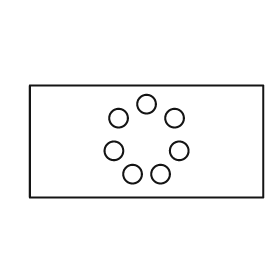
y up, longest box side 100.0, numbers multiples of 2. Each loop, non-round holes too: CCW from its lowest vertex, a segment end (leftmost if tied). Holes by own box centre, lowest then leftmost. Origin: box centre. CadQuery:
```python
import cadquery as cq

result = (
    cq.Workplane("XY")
    .moveTo(-50.0, -24.0)
    .lineTo(50.0, -24.0)
    .lineTo(50.0, 24.0)
    .lineTo(-50.0, 24.0)
    .close()
    .moveTo(-6.0, -14.0)
    .circle(4.0)
    .moveTo(6.0, -14.0)
    .circle(4.0)
    .moveTo(-14.0, -4.0)
    .circle(4.0)
    .moveTo(14.0, -4.0)
    .circle(4.0)
    .moveTo(-12.0, 10.0)
    .circle(4.0)
    .moveTo(12.0, 10.0)
    .circle(4.0)
    .moveTo(0.0, 16.0)
    .circle(4.0)
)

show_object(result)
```